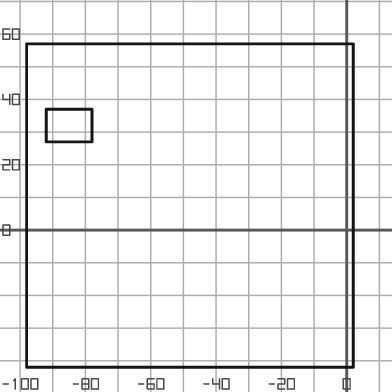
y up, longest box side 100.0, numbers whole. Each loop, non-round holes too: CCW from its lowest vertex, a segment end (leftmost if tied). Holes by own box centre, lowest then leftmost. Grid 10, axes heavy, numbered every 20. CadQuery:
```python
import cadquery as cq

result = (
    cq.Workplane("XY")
    .moveTo(-98.0, -42.0)
    .lineTo(2.0, -42.0)
    .lineTo(2.0, 57.0)
    .lineTo(-98.0, 57.0)
    .close()
    .moveTo(-92.0, 27.0)
    .lineTo(-78.0, 27.0)
    .lineTo(-78.0, 37.0)
    .lineTo(-92.0, 37.0)
    .close()
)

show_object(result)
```